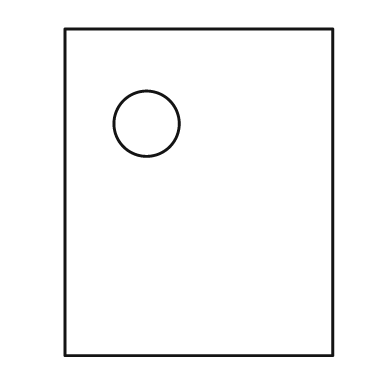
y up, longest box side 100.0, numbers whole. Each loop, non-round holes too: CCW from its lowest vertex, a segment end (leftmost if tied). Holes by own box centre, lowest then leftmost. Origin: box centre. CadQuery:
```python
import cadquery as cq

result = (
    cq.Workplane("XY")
    .moveTo(-41.0, -50.0)
    .lineTo(41.0, -50.0)
    .lineTo(41.0, 50.0)
    .lineTo(-41.0, 50.0)
    .close()
    .moveTo(-16.0, 21.0)
    .circle(10.0)
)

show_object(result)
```